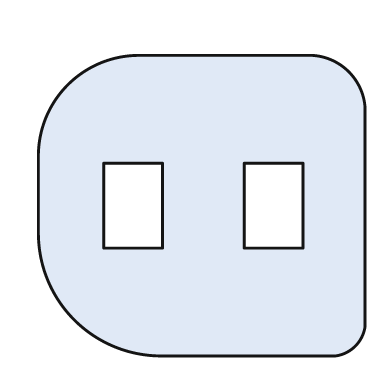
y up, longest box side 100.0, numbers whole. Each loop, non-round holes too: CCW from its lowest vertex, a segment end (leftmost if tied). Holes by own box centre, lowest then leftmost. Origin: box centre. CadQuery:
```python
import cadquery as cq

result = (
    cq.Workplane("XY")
    .moveTo(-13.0, -46.0)
    .lineTo(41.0, -46.0)
    .threePointArc((47.0, -43.0), (50.0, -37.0))
    .lineTo(50.0, 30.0)
    .threePointArc((45.0, 41.0), (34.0, 46.0))
    .lineTo(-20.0, 46.0)
    .threePointArc((-41.0, 37.0), (-50.0, 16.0))
    .lineTo(-50.0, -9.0)
    .threePointArc((-39.0, -35.0), (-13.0, -46.0))
    .close()
    .moveTo(-30.0, -13.0)
    .lineTo(-12.0, -13.0)
    .lineTo(-12.0, 13.0)
    .lineTo(-30.0, 13.0)
    .close()
    .moveTo(13.0, -13.0)
    .lineTo(31.0, -13.0)
    .lineTo(31.0, 13.0)
    .lineTo(13.0, 13.0)
    .close()
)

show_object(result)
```